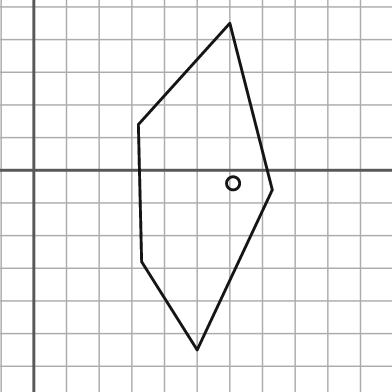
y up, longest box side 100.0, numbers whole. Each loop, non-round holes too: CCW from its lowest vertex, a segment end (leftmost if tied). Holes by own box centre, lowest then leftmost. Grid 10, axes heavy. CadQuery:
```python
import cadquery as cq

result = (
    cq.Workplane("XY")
    .moveTo(50.0, -55.0)
    .lineTo(73.0, -6.0)
    .lineTo(60.0, 45.0)
    .lineTo(32.0, 14.0)
    .lineTo(33.0, -28.0)
    .close()
    .moveTo(61.0, -4.0)
    .circle(2.0)
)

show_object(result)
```